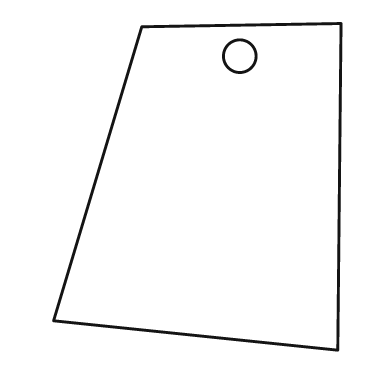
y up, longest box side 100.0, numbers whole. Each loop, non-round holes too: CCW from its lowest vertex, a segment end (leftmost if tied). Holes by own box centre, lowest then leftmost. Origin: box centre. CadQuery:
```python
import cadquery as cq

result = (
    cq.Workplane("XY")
    .moveTo(43.0, -50.0)
    .lineTo(44.0, 50.0)
    .lineTo(-17.0, 49.0)
    .lineTo(-44.0, -41.0)
    .close()
    .moveTo(13.0, 40.0)
    .circle(5.0)
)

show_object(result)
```